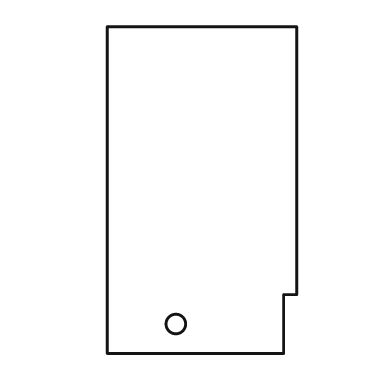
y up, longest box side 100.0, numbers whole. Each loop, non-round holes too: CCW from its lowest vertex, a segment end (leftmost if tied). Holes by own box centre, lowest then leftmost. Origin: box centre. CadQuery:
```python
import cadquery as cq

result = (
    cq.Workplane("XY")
    .moveTo(-29.0, -50.0)
    .lineTo(25.0, -50.0)
    .lineTo(25.0, -32.0)
    .lineTo(29.0, -32.0)
    .lineTo(29.0, 50.0)
    .lineTo(-29.0, 50.0)
    .close()
    .moveTo(-8.0, -41.0)
    .circle(3.0)
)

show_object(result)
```